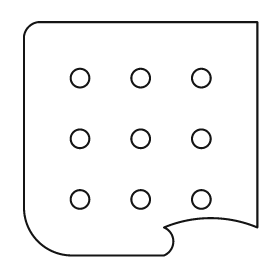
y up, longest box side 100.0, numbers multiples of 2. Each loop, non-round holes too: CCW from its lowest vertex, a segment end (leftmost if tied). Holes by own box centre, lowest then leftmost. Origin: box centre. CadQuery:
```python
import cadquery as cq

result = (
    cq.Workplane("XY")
    .moveTo(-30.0, -50.0)
    .lineTo(10.0, -50.0)
    .threePointArc((14.0, -44.0), (10.0, -38.0))
    .threePointArc((30.0, -34.0), (50.0, -38.0))
    .lineTo(50.0, 50.0)
    .lineTo(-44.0, 50.0)
    .threePointArc((-48.0, 48.0), (-50.0, 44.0))
    .lineTo(-50.0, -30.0)
    .threePointArc((-44.0, -44.0), (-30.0, -50.0))
    .close()
    .moveTo(-26.0, -26.0)
    .circle(4.0)
    .moveTo(0.0, -26.0)
    .circle(4.0)
    .moveTo(26.0, -26.0)
    .circle(4.0)
    .moveTo(-26.0, 0.0)
    .circle(4.0)
    .moveTo(0.0, 0.0)
    .circle(4.0)
    .moveTo(26.0, 0.0)
    .circle(4.0)
    .moveTo(-26.0, 26.0)
    .circle(4.0)
    .moveTo(0.0, 26.0)
    .circle(4.0)
    .moveTo(26.0, 26.0)
    .circle(4.0)
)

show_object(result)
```